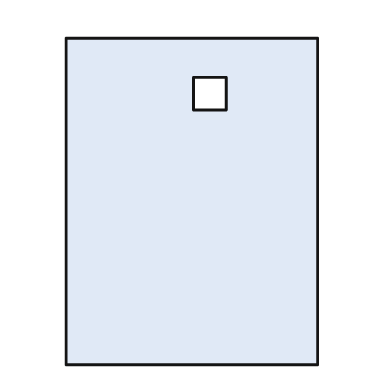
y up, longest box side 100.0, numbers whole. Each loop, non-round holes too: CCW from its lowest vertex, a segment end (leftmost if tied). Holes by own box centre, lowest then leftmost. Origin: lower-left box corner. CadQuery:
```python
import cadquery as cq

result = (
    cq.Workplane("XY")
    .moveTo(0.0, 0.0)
    .lineTo(77.0, 0.0)
    .lineTo(77.0, 100.0)
    .lineTo(0.0, 100.0)
    .close()
    .moveTo(39.0, 78.0)
    .lineTo(49.0, 78.0)
    .lineTo(49.0, 88.0)
    .lineTo(39.0, 88.0)
    .close()
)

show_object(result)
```